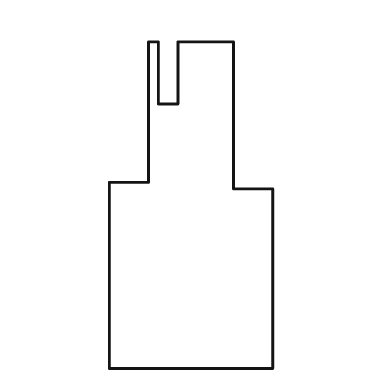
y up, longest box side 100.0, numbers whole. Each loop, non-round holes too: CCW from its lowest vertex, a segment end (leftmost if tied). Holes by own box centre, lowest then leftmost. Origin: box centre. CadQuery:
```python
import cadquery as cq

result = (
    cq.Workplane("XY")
    .moveTo(-25.0, -50.0)
    .lineTo(25.0, -50.0)
    .lineTo(25.0, 5.0)
    .lineTo(13.0, 5.0)
    .lineTo(13.0, 50.0)
    .lineTo(-4.0, 50.0)
    .lineTo(-4.0, 31.0)
    .lineTo(-10.0, 31.0)
    .lineTo(-10.0, 50.0)
    .lineTo(-13.0, 50.0)
    .lineTo(-13.0, 7.0)
    .lineTo(-25.0, 7.0)
    .close()
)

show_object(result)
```